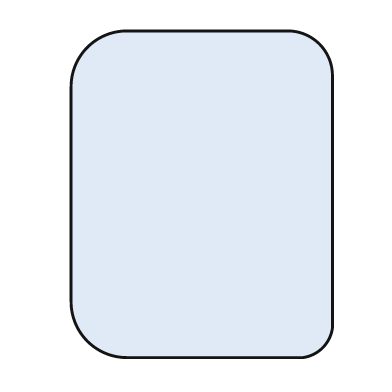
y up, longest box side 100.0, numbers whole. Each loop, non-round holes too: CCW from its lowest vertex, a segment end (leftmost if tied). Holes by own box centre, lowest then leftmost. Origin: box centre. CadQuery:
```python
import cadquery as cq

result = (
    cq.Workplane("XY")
    .moveTo(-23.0, -50.0)
    .lineTo(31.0, -50.0)
    .threePointArc((37.0, -47.0), (40.0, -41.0))
    .lineTo(40.0, 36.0)
    .threePointArc((36.0, 46.0), (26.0, 50.0))
    .lineTo(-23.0, 50.0)
    .threePointArc((-35.0, 45.0), (-40.0, 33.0))
    .lineTo(-40.0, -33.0)
    .threePointArc((-35.0, -45.0), (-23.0, -50.0))
    .close()
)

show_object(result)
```